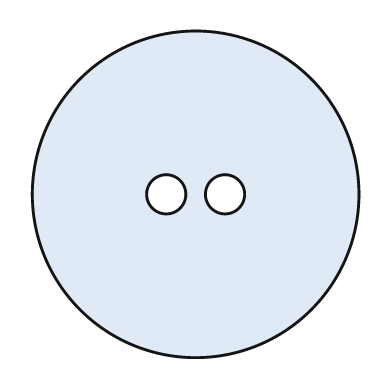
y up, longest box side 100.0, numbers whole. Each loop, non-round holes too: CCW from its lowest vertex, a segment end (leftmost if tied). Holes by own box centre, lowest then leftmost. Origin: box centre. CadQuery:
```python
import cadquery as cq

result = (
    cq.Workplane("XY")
    .moveTo(0.0, 0.0)
    .circle(50.0)
    .moveTo(-9.0, 0.0)
    .circle(6.0)
    .moveTo(9.0, 0.0)
    .circle(6.0)
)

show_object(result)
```